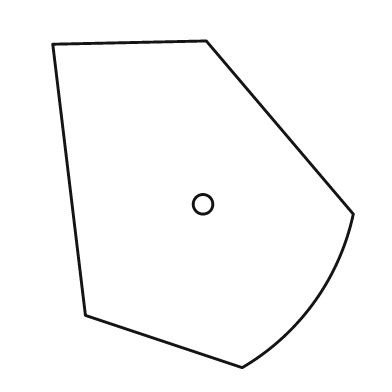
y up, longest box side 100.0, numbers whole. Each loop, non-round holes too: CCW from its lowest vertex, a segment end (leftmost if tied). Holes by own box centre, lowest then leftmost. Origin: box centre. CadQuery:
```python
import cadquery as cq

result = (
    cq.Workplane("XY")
    .moveTo(12.0, -50.0)
    .threePointArc((34.0, -30.0), (46.0, -3.0))
    .lineTo(1.0, 50.0)
    .lineTo(-46.0, 49.0)
    .lineTo(-36.0, -34.0)
    .close()
    .moveTo(0.0, 0.0)
    .circle(3.0)
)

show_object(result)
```